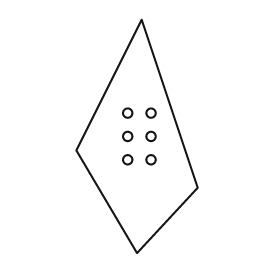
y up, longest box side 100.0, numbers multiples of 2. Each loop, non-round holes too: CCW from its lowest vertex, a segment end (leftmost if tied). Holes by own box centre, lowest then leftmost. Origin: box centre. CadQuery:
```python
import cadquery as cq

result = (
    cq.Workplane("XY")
    .moveTo(0.0, -50.0)
    .lineTo(26.0, -22.0)
    .lineTo(2.0, 50.0)
    .lineTo(-26.0, -6.0)
    .close()
    .moveTo(-4.0, -10.0)
    .circle(2.0)
    .moveTo(6.0, -10.0)
    .circle(2.0)
    .moveTo(-4.0, 0.0)
    .circle(2.0)
    .moveTo(6.0, 0.0)
    .circle(2.0)
    .moveTo(-4.0, 10.0)
    .circle(2.0)
    .moveTo(6.0, 10.0)
    .circle(2.0)
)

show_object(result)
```